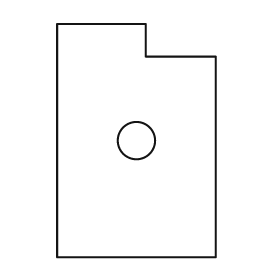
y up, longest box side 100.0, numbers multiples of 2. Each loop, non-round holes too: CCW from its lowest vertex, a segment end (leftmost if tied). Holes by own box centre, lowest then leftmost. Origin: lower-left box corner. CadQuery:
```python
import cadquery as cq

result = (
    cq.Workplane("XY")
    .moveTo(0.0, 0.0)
    .lineTo(68.0, 0.0)
    .lineTo(68.0, 86.0)
    .lineTo(38.0, 86.0)
    .lineTo(38.0, 100.0)
    .lineTo(0.0, 100.0)
    .close()
    .moveTo(34.0, 50.0)
    .circle(8.0)
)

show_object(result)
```